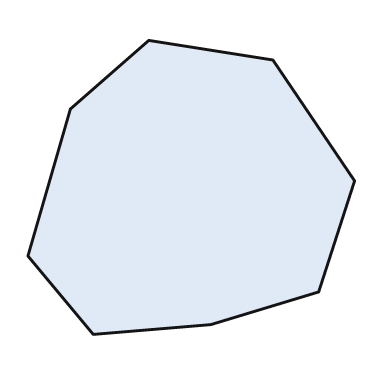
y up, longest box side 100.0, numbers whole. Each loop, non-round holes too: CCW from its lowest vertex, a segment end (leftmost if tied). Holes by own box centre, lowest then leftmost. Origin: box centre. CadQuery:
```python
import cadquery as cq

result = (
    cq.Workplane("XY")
    .moveTo(-30.0, -45.0)
    .lineTo(6.0, -42.0)
    .lineTo(39.0, -32.0)
    .lineTo(50.0, 2.0)
    .lineTo(25.0, 39.0)
    .lineTo(-13.0, 45.0)
    .lineTo(-37.0, 24.0)
    .lineTo(-50.0, -21.0)
    .close()
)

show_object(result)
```